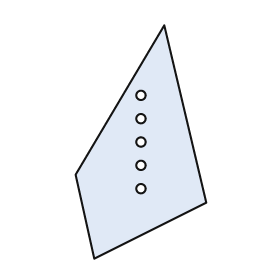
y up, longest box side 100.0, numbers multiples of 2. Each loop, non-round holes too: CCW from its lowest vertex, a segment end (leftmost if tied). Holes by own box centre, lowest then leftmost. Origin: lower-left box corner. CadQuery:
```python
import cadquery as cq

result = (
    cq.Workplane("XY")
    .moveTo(8.0, 0.0)
    .lineTo(56.0, 24.0)
    .lineTo(38.0, 100.0)
    .lineTo(0.0, 36.0)
    .close()
    .moveTo(28.0, 30.0)
    .circle(2.0)
    .moveTo(28.0, 40.0)
    .circle(2.0)
    .moveTo(28.0, 50.0)
    .circle(2.0)
    .moveTo(28.0, 60.0)
    .circle(2.0)
    .moveTo(28.0, 70.0)
    .circle(2.0)
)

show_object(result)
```